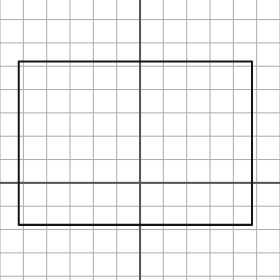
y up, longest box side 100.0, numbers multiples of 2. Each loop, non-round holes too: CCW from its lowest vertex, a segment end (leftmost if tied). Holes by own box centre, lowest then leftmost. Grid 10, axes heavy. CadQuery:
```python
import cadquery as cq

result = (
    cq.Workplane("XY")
    .moveTo(-52.0, -18.0)
    .lineTo(48.0, -18.0)
    .lineTo(48.0, 52.0)
    .lineTo(-52.0, 52.0)
    .close()
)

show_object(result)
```